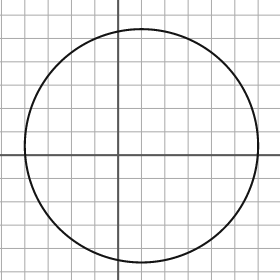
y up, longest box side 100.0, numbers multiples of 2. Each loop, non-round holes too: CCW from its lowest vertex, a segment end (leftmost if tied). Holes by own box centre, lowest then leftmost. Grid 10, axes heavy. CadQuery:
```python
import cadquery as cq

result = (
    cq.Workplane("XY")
    .moveTo(10.0, 4.0)
    .circle(50.0)
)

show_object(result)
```